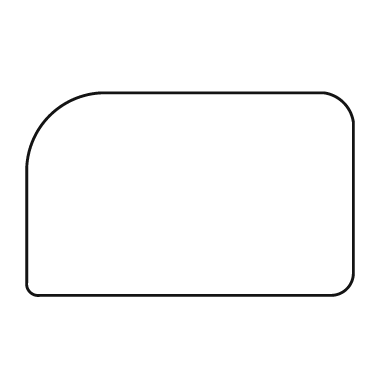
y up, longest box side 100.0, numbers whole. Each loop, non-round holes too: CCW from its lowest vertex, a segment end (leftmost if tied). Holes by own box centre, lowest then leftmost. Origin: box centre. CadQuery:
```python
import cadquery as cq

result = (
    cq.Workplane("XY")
    .moveTo(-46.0, -31.0)
    .lineTo(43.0, -31.0)
    .threePointArc((48.0, -29.0), (50.0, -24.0))
    .lineTo(50.0, 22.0)
    .threePointArc((47.0, 28.0), (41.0, 31.0))
    .lineTo(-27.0, 31.0)
    .threePointArc((-43.0, 24.0), (-50.0, 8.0))
    .lineTo(-50.0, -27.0)
    .threePointArc((-49.0, -30.0), (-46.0, -31.0))
    .close()
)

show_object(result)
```